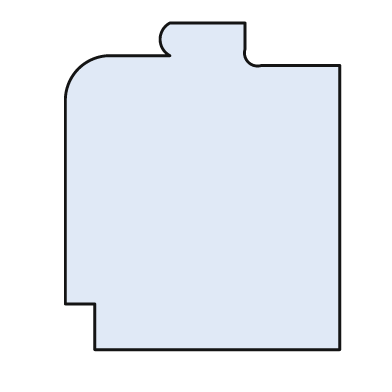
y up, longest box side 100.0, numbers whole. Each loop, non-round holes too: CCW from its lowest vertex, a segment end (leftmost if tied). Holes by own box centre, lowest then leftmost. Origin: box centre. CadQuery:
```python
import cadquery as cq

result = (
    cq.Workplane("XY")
    .moveTo(-33.0, -50.0)
    .lineTo(42.0, -50.0)
    .lineTo(42.0, 37.0)
    .lineTo(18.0, 37.0)
    .threePointArc((14.0, 38.0), (13.0, 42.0))
    .lineTo(13.0, 50.0)
    .lineTo(-10.0, 50.0)
    .threePointArc((-13.0, 45.0), (-10.0, 40.0))
    .lineTo(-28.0, 40.0)
    .threePointArc((-38.0, 36.0), (-42.0, 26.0))
    .lineTo(-42.0, -36.0)
    .lineTo(-33.0, -36.0)
    .close()
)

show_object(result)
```